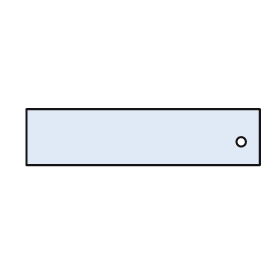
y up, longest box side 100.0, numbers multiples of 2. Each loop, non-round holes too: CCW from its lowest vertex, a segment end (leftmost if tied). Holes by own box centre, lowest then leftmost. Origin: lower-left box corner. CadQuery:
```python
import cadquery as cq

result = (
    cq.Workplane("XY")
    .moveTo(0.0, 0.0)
    .lineTo(100.0, 0.0)
    .lineTo(100.0, 24.0)
    .lineTo(0.0, 24.0)
    .close()
    .moveTo(92.0, 10.0)
    .circle(2.0)
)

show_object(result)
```